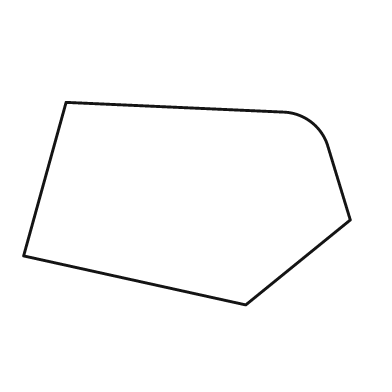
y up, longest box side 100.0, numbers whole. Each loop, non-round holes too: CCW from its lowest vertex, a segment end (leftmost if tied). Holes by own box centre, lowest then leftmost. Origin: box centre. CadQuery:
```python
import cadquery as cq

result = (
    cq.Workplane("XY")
    .moveTo(18.0, -31.0)
    .lineTo(50.0, -5.0)
    .lineTo(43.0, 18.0)
    .threePointArc((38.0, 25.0), (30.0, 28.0))
    .lineTo(-37.0, 31.0)
    .lineTo(-50.0, -16.0)
    .close()
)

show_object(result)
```